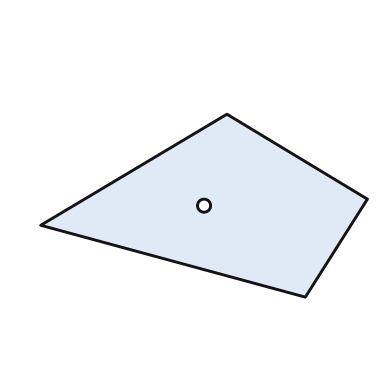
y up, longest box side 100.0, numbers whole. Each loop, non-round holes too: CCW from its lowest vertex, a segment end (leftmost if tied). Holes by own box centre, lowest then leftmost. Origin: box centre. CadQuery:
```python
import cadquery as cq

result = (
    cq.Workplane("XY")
    .moveTo(31.0, -28.0)
    .lineTo(50.0, 2.0)
    .lineTo(7.0, 28.0)
    .lineTo(-50.0, -6.0)
    .close()
    .moveTo(0.0, 0.0)
    .circle(2.0)
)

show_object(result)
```